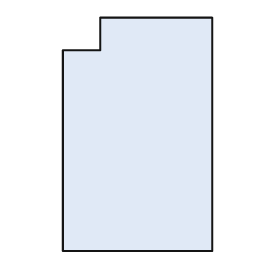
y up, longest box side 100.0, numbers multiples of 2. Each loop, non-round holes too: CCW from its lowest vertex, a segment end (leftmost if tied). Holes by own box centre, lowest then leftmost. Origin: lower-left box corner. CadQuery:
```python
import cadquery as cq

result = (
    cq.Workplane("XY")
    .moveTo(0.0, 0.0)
    .lineTo(64.0, 0.0)
    .lineTo(64.0, 100.0)
    .lineTo(16.0, 100.0)
    .lineTo(16.0, 86.0)
    .lineTo(0.0, 86.0)
    .close()
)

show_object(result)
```